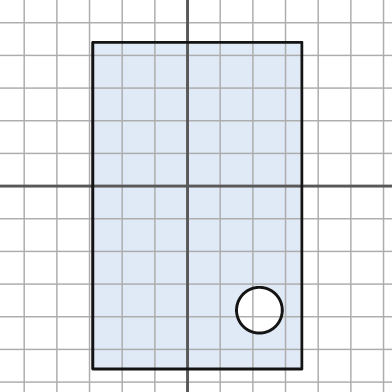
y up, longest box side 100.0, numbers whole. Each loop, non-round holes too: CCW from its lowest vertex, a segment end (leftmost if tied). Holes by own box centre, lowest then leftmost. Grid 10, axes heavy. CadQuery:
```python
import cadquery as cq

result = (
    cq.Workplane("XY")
    .moveTo(-29.0, -56.0)
    .lineTo(35.0, -56.0)
    .lineTo(35.0, 44.0)
    .lineTo(-29.0, 44.0)
    .close()
    .moveTo(22.0, -38.0)
    .circle(7.0)
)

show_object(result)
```